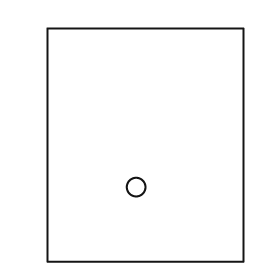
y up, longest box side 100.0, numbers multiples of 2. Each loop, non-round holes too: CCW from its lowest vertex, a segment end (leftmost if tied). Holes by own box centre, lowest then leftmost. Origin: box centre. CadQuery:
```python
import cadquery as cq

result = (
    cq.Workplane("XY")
    .moveTo(-42.0, -50.0)
    .lineTo(42.0, -50.0)
    .lineTo(42.0, 50.0)
    .lineTo(-42.0, 50.0)
    .close()
    .moveTo(-4.0, -18.0)
    .circle(4.0)
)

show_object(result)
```